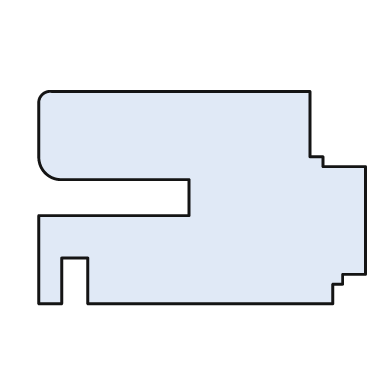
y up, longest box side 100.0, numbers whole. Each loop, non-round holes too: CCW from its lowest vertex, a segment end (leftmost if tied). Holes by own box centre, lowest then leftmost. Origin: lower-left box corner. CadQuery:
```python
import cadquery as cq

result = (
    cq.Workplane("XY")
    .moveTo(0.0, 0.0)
    .lineTo(7.0, 0.0)
    .lineTo(7.0, 14.0)
    .lineTo(15.0, 14.0)
    .lineTo(15.0, 0.0)
    .lineTo(90.0, 0.0)
    .lineTo(90.0, 6.0)
    .lineTo(93.0, 6.0)
    .lineTo(93.0, 9.0)
    .lineTo(100.0, 9.0)
    .lineTo(100.0, 42.0)
    .lineTo(87.0, 42.0)
    .lineTo(87.0, 45.0)
    .lineTo(83.0, 45.0)
    .lineTo(83.0, 65.0)
    .lineTo(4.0, 65.0)
    .threePointArc((1.0, 64.0), (0.0, 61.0))
    .lineTo(0.0, 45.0)
    .threePointArc((2.0, 40.0), (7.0, 38.0))
    .lineTo(46.0, 38.0)
    .lineTo(46.0, 27.0)
    .lineTo(0.0, 27.0)
    .close()
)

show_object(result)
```